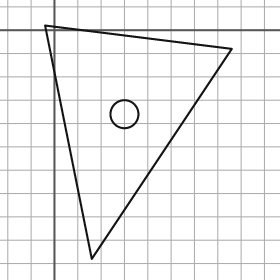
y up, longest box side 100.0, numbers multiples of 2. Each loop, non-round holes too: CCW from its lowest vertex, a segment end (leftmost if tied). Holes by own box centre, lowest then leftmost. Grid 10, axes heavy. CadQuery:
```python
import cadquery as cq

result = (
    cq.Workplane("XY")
    .moveTo(16.0, -98.0)
    .lineTo(76.0, -8.0)
    .lineTo(-4.0, 2.0)
    .close()
    .moveTo(30.0, -36.0)
    .circle(6.0)
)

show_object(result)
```